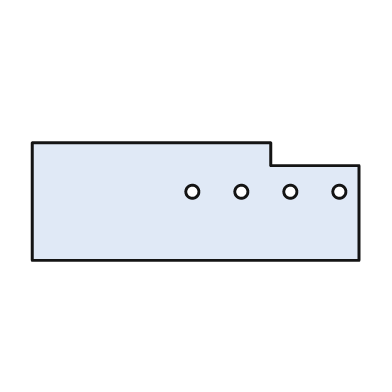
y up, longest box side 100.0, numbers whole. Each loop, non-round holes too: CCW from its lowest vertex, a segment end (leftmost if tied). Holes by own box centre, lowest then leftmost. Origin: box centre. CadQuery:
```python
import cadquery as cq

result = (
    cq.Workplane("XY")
    .moveTo(-50.0, -18.0)
    .lineTo(50.0, -18.0)
    .lineTo(50.0, 11.0)
    .lineTo(23.0, 11.0)
    .lineTo(23.0, 18.0)
    .lineTo(-50.0, 18.0)
    .close()
    .moveTo(-1.0, 3.0)
    .circle(2.0)
    .moveTo(14.0, 3.0)
    .circle(2.0)
    .moveTo(29.0, 3.0)
    .circle(2.0)
    .moveTo(44.0, 3.0)
    .circle(2.0)
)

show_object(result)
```